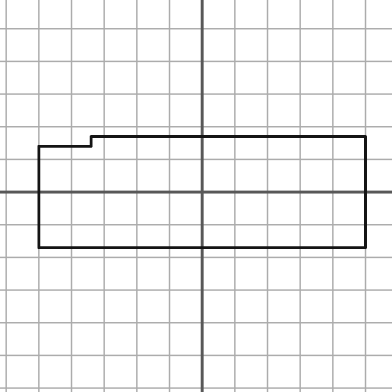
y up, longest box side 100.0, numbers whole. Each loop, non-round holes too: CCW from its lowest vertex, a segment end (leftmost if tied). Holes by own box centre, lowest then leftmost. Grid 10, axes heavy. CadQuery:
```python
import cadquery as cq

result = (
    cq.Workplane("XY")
    .moveTo(-50.0, -17.0)
    .lineTo(50.0, -17.0)
    .lineTo(50.0, 17.0)
    .lineTo(-34.0, 17.0)
    .lineTo(-34.0, 14.0)
    .lineTo(-50.0, 14.0)
    .close()
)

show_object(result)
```